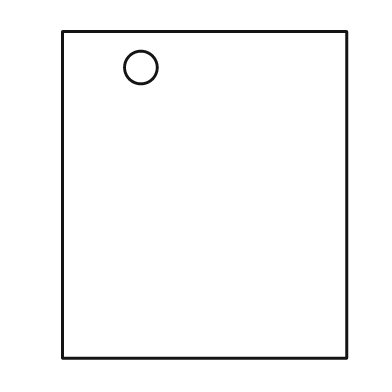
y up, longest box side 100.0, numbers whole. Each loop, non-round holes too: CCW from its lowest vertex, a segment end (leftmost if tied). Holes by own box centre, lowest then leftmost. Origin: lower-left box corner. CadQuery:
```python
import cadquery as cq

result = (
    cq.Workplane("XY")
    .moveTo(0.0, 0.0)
    .lineTo(87.0, 0.0)
    .lineTo(87.0, 100.0)
    .lineTo(0.0, 100.0)
    .close()
    .moveTo(24.0, 89.0)
    .circle(5.0)
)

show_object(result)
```